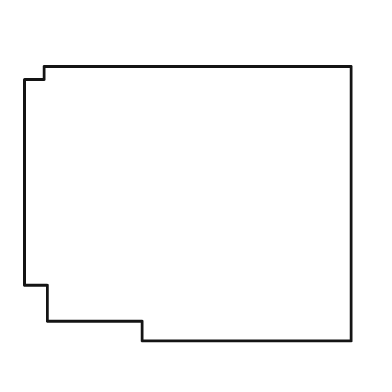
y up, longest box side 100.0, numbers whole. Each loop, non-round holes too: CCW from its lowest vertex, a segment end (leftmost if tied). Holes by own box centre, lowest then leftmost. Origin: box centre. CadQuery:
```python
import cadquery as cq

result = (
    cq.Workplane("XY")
    .moveTo(-14.0, -42.0)
    .lineTo(50.0, -42.0)
    .lineTo(50.0, 42.0)
    .lineTo(-44.0, 42.0)
    .lineTo(-44.0, 38.0)
    .lineTo(-50.0, 38.0)
    .lineTo(-50.0, -25.0)
    .lineTo(-43.0, -25.0)
    .lineTo(-43.0, -36.0)
    .lineTo(-14.0, -36.0)
    .close()
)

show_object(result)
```